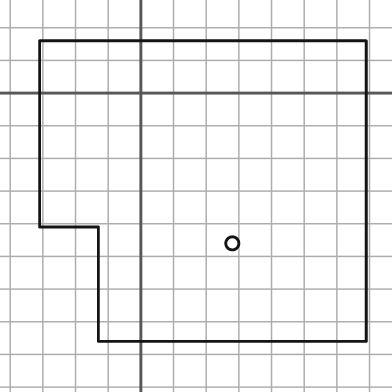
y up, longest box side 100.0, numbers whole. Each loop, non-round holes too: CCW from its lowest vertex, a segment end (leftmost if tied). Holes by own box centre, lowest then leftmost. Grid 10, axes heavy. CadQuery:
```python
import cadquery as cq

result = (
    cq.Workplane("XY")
    .moveTo(-13.0, -76.0)
    .lineTo(69.0, -76.0)
    .lineTo(69.0, 16.0)
    .lineTo(-31.0, 16.0)
    .lineTo(-31.0, -41.0)
    .lineTo(-13.0, -41.0)
    .close()
    .moveTo(28.0, -46.0)
    .circle(2.0)
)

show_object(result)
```